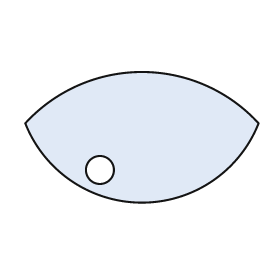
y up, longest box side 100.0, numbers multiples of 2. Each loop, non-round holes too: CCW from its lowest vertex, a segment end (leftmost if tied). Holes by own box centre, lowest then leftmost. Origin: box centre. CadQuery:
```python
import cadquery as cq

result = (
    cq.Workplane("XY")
    .moveTo(-50.0, 6.0)
    .threePointArc((0.0, -28.0), (50.0, 6.0))
    .threePointArc((0.0, 28.0), (-50.0, 6.0))
    .close()
    .moveTo(-18.0, -14.0)
    .circle(6.0)
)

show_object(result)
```